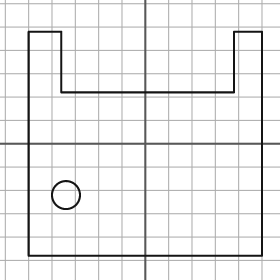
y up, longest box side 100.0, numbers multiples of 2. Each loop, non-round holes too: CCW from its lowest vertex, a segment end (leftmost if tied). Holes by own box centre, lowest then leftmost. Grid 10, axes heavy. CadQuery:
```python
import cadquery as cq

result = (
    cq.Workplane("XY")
    .moveTo(-50.0, -48.0)
    .lineTo(50.0, -48.0)
    .lineTo(50.0, 48.0)
    .lineTo(38.0, 48.0)
    .lineTo(38.0, 22.0)
    .lineTo(-36.0, 22.0)
    .lineTo(-36.0, 48.0)
    .lineTo(-50.0, 48.0)
    .close()
    .moveTo(-34.0, -22.0)
    .circle(6.0)
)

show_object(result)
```